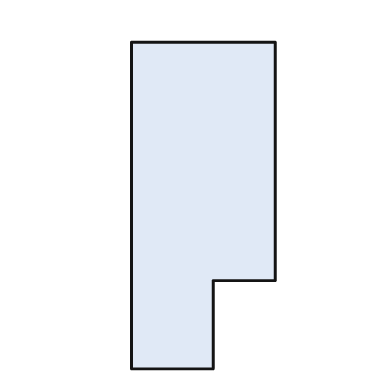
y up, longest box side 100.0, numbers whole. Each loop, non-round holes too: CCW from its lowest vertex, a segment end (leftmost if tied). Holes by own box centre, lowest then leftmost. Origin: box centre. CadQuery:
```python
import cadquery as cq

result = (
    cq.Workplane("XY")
    .moveTo(-22.0, -50.0)
    .lineTo(3.0, -50.0)
    .lineTo(3.0, -23.0)
    .lineTo(22.0, -23.0)
    .lineTo(22.0, 50.0)
    .lineTo(-22.0, 50.0)
    .close()
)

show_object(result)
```